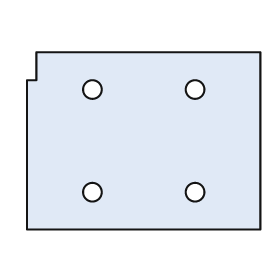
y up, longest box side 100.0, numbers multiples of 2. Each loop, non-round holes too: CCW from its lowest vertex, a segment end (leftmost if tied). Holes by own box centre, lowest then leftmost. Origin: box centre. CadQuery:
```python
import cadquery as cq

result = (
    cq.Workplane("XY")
    .moveTo(-50.0, -38.0)
    .lineTo(50.0, -38.0)
    .lineTo(50.0, 38.0)
    .lineTo(-46.0, 38.0)
    .lineTo(-46.0, 26.0)
    .lineTo(-50.0, 26.0)
    .close()
    .moveTo(-22.0, -22.0)
    .circle(4.0)
    .moveTo(22.0, -22.0)
    .circle(4.0)
    .moveTo(-22.0, 22.0)
    .circle(4.0)
    .moveTo(22.0, 22.0)
    .circle(4.0)
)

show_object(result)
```